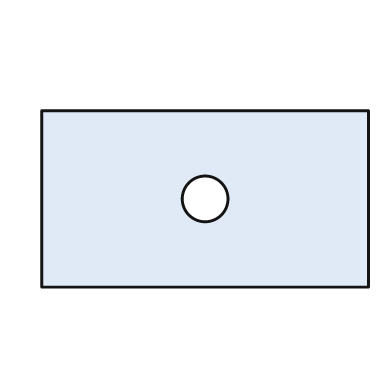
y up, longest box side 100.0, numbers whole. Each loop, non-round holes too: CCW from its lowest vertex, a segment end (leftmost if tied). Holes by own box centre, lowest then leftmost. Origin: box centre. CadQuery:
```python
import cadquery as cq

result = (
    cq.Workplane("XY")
    .moveTo(-50.0, -27.0)
    .lineTo(50.0, -27.0)
    .lineTo(50.0, 27.0)
    .lineTo(-50.0, 27.0)
    .close()
    .moveTo(0.0, 0.0)
    .circle(7.0)
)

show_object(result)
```